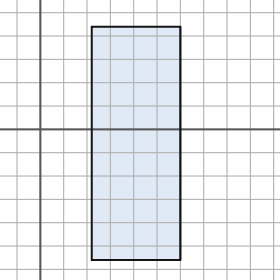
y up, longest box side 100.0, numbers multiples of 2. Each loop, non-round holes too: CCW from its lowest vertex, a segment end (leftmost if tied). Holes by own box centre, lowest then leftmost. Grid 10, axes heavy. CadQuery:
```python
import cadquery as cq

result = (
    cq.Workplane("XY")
    .moveTo(22.0, -56.0)
    .lineTo(60.0, -56.0)
    .lineTo(60.0, 44.0)
    .lineTo(22.0, 44.0)
    .close()
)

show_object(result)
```